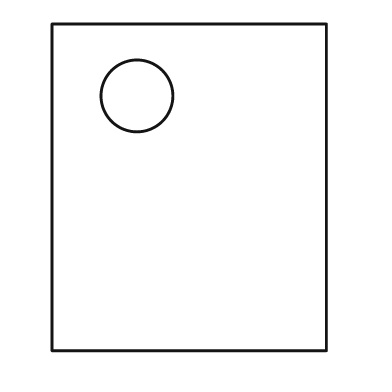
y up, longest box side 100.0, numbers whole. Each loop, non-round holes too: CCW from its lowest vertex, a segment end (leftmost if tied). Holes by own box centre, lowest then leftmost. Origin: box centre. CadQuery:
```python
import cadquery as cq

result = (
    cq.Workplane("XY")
    .moveTo(-42.0, -50.0)
    .lineTo(42.0, -50.0)
    .lineTo(42.0, 50.0)
    .lineTo(-42.0, 50.0)
    .close()
    .moveTo(-16.0, 28.0)
    .circle(11.0)
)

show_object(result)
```